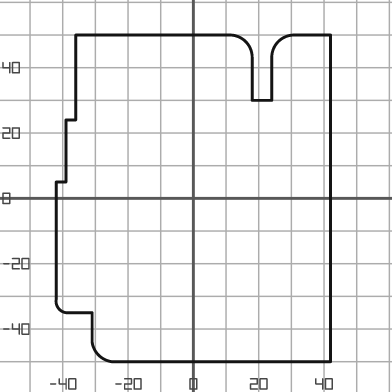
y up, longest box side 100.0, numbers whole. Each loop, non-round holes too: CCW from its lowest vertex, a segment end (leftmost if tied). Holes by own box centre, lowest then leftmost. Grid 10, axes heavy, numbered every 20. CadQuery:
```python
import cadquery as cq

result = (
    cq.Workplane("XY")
    .moveTo(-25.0, -50.0)
    .lineTo(42.0, -50.0)
    .lineTo(42.0, 50.0)
    .lineTo(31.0, 50.0)
    .threePointArc((26.0, 48.0), (24.0, 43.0))
    .lineTo(24.0, 30.0)
    .lineTo(18.0, 30.0)
    .lineTo(18.0, 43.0)
    .threePointArc((16.0, 48.0), (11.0, 50.0))
    .lineTo(-36.0, 50.0)
    .lineTo(-36.0, 24.0)
    .lineTo(-39.0, 24.0)
    .lineTo(-39.0, 5.0)
    .lineTo(-42.0, 5.0)
    .lineTo(-42.0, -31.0)
    .threePointArc((-41.0, -34.0), (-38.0, -35.0))
    .lineTo(-31.0, -35.0)
    .lineTo(-31.0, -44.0)
    .threePointArc((-29.0, -48.0), (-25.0, -50.0))
    .close()
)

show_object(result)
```